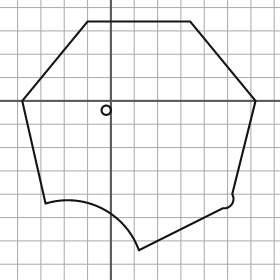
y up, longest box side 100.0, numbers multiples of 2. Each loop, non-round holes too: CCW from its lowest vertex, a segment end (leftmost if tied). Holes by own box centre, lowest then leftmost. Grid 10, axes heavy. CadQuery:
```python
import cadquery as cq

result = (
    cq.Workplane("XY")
    .moveTo(12.0, -64.0)
    .lineTo(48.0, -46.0)
    .threePointArc((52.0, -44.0), (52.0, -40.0))
    .lineTo(62.0, 0.0)
    .lineTo(34.0, 34.0)
    .lineTo(-10.0, 34.0)
    .lineTo(-38.0, 0.0)
    .lineTo(-28.0, -44.0)
    .threePointArc((-4.0, -46.0), (12.0, -64.0))
    .close()
    .moveTo(-2.0, -4.0)
    .circle(2.0)
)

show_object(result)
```